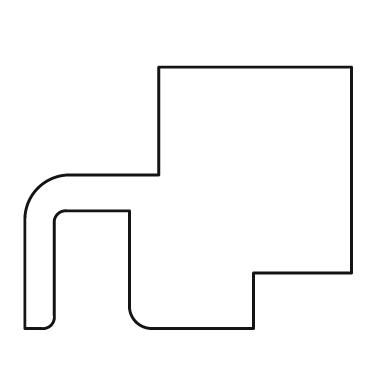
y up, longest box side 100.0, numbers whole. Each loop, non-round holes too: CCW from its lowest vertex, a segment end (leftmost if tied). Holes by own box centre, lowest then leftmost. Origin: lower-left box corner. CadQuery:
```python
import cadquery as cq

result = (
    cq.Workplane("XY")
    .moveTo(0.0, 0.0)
    .lineTo(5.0, 0.0)
    .threePointArc((8.0, 1.0), (9.0, 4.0))
    .lineTo(9.0, 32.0)
    .threePointArc((10.0, 35.0), (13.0, 36.0))
    .lineTo(32.0, 36.0)
    .lineTo(32.0, 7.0)
    .threePointArc((34.0, 2.0), (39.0, 0.0))
    .lineTo(70.0, 0.0)
    .lineTo(70.0, 17.0)
    .lineTo(100.0, 17.0)
    .lineTo(100.0, 80.0)
    .lineTo(41.0, 80.0)
    .lineTo(41.0, 47.0)
    .lineTo(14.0, 47.0)
    .threePointArc((4.0, 43.0), (0.0, 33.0))
    .close()
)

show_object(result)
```